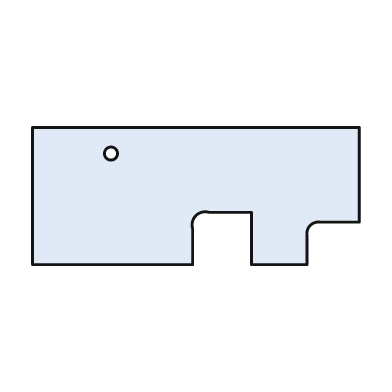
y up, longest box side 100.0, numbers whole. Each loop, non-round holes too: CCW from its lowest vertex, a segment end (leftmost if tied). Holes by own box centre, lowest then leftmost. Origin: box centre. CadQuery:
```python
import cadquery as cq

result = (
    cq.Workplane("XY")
    .moveTo(-50.0, -21.0)
    .lineTo(-1.0, -21.0)
    .lineTo(-1.0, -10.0)
    .threePointArc((0.0, -6.0), (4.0, -5.0))
    .lineTo(17.0, -5.0)
    .lineTo(17.0, -21.0)
    .lineTo(34.0, -21.0)
    .lineTo(34.0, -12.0)
    .threePointArc((35.0, -9.0), (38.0, -8.0))
    .lineTo(50.0, -8.0)
    .lineTo(50.0, 21.0)
    .lineTo(-50.0, 21.0)
    .close()
    .moveTo(-26.0, 13.0)
    .circle(2.0)
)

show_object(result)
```